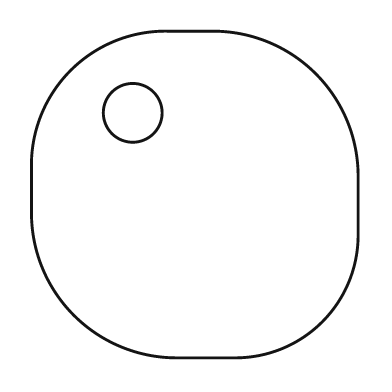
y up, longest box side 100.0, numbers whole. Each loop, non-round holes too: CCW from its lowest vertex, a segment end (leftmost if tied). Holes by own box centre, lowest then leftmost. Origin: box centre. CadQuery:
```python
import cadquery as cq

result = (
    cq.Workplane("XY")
    .moveTo(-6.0, -50.0)
    .lineTo(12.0, -50.0)
    .threePointArc((39.0, -39.0), (50.0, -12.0))
    .lineTo(50.0, 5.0)
    .threePointArc((37.0, 37.0), (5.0, 50.0))
    .lineTo(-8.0, 50.0)
    .threePointArc((-38.0, 38.0), (-50.0, 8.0))
    .lineTo(-50.0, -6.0)
    .threePointArc((-37.0, -37.0), (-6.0, -50.0))
    .close()
    .moveTo(-19.0, 25.0)
    .circle(9.0)
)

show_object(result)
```